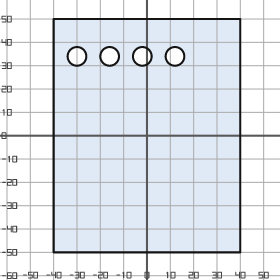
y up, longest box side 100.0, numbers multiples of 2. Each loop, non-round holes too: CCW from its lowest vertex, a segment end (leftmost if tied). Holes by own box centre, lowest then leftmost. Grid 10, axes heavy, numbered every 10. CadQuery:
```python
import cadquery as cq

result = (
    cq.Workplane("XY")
    .moveTo(-40.0, -50.0)
    .lineTo(40.0, -50.0)
    .lineTo(40.0, 50.0)
    .lineTo(-40.0, 50.0)
    .close()
    .moveTo(-30.0, 34.0)
    .circle(4.0)
    .moveTo(-16.0, 34.0)
    .circle(4.0)
    .moveTo(-2.0, 34.0)
    .circle(4.0)
    .moveTo(12.0, 34.0)
    .circle(4.0)
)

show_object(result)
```